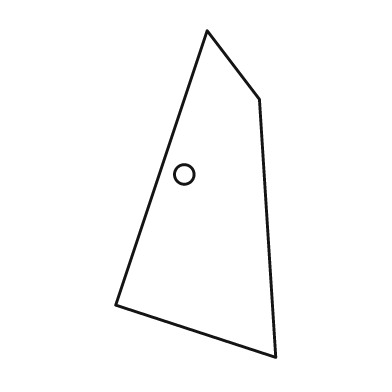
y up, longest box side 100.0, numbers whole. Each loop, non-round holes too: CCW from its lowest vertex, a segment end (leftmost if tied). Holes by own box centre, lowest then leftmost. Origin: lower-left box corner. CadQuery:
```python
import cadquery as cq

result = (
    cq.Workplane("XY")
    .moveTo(49.0, 0.0)
    .lineTo(44.0, 79.0)
    .lineTo(28.0, 100.0)
    .lineTo(0.0, 16.0)
    .close()
    .moveTo(21.0, 56.0)
    .circle(3.0)
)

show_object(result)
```